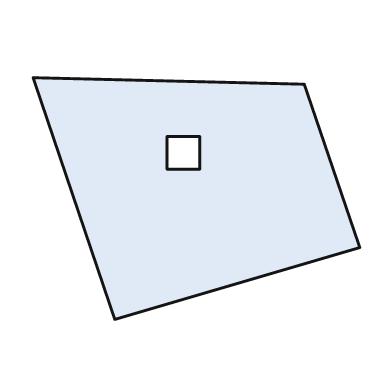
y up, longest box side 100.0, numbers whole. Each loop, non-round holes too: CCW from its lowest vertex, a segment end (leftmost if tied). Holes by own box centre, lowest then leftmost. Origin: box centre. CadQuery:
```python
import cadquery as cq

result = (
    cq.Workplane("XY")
    .moveTo(-25.0, -37.0)
    .lineTo(50.0, -15.0)
    .lineTo(33.0, 35.0)
    .lineTo(-50.0, 37.0)
    .close()
    .moveTo(-9.0, 9.0)
    .lineTo(1.0, 9.0)
    .lineTo(1.0, 19.0)
    .lineTo(-9.0, 19.0)
    .close()
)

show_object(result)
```